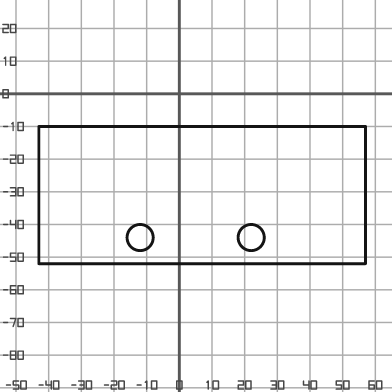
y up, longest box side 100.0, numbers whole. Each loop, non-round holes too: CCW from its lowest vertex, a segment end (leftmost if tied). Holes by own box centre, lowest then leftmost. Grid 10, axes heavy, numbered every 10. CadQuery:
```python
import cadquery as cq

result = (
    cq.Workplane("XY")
    .moveTo(-43.0, -52.0)
    .lineTo(57.0, -52.0)
    .lineTo(57.0, -10.0)
    .lineTo(-43.0, -10.0)
    .close()
    .moveTo(-12.0, -44.0)
    .circle(4.0)
    .moveTo(22.0, -44.0)
    .circle(4.0)
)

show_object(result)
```